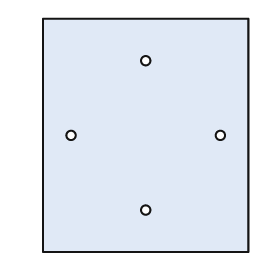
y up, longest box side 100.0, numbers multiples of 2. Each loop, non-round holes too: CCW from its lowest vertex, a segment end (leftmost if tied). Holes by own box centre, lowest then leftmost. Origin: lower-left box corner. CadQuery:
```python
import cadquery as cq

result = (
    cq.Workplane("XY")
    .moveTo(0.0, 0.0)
    .lineTo(88.0, 0.0)
    .lineTo(88.0, 100.0)
    .lineTo(0.0, 100.0)
    .close()
    .moveTo(44.0, 18.0)
    .circle(2.0)
    .moveTo(12.0, 50.0)
    .circle(2.0)
    .moveTo(76.0, 50.0)
    .circle(2.0)
    .moveTo(44.0, 82.0)
    .circle(2.0)
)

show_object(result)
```